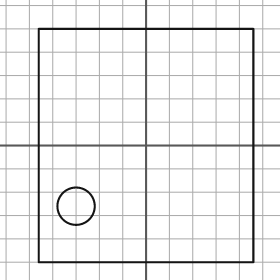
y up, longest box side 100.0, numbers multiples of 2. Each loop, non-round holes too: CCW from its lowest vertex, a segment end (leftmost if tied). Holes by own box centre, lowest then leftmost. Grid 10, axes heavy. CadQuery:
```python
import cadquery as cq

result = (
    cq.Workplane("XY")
    .moveTo(-46.0, -50.0)
    .lineTo(46.0, -50.0)
    .lineTo(46.0, 50.0)
    .lineTo(-46.0, 50.0)
    .close()
    .moveTo(-30.0, -26.0)
    .circle(8.0)
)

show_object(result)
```